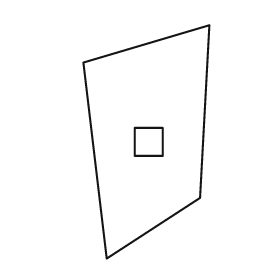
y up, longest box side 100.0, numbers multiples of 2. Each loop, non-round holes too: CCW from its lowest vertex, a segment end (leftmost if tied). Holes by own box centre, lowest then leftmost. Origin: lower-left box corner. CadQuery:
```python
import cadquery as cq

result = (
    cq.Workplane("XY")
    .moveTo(10.0, 0.0)
    .lineTo(50.0, 26.0)
    .lineTo(54.0, 100.0)
    .lineTo(0.0, 84.0)
    .close()
    .moveTo(22.0, 44.0)
    .lineTo(34.0, 44.0)
    .lineTo(34.0, 56.0)
    .lineTo(22.0, 56.0)
    .close()
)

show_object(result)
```